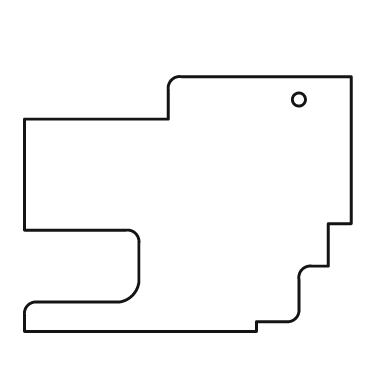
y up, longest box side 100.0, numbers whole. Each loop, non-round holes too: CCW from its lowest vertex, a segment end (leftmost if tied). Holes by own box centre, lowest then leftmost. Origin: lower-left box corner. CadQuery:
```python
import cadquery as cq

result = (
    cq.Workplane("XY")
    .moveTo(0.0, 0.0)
    .lineTo(71.0, 0.0)
    .lineTo(71.0, 3.0)
    .lineTo(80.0, 3.0)
    .threePointArc((83.0, 4.0), (84.0, 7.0))
    .lineTo(84.0, 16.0)
    .threePointArc((85.0, 19.0), (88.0, 20.0))
    .lineTo(93.0, 20.0)
    .lineTo(93.0, 33.0)
    .lineTo(100.0, 33.0)
    .lineTo(100.0, 78.0)
    .lineTo(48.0, 78.0)
    .threePointArc((45.0, 77.0), (44.0, 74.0))
    .lineTo(44.0, 65.0)
    .lineTo(0.0, 65.0)
    .lineTo(0.0, 31.0)
    .lineTo(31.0, 31.0)
    .threePointArc((34.0, 30.0), (35.0, 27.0))
    .lineTo(35.0, 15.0)
    .threePointArc((33.0, 11.0), (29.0, 9.0))
    .lineTo(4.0, 9.0)
    .threePointArc((1.0, 8.0), (0.0, 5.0))
    .close()
    .moveTo(84.0, 71.0)
    .circle(2.0)
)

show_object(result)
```